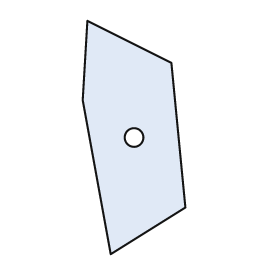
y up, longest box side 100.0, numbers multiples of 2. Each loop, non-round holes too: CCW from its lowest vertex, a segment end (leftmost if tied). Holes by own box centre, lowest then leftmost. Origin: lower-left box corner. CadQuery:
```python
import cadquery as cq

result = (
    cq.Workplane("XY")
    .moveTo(12.0, 0.0)
    .lineTo(44.0, 20.0)
    .lineTo(38.0, 82.0)
    .lineTo(2.0, 100.0)
    .lineTo(0.0, 66.0)
    .close()
    .moveTo(22.0, 50.0)
    .circle(4.0)
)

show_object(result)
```